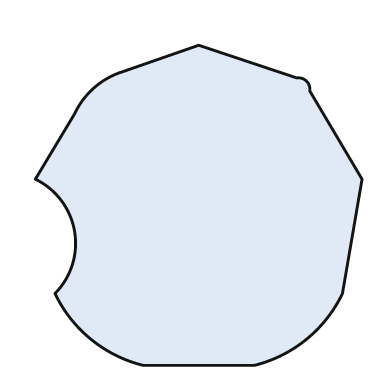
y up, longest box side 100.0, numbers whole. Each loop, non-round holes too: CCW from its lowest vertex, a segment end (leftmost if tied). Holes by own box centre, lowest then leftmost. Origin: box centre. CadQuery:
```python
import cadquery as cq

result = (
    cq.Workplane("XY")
    .moveTo(-17.0, -49.0)
    .lineTo(17.0, -49.0)
    .threePointArc((33.0, -41.0), (44.0, -27.0))
    .lineTo(50.0, 8.0)
    .lineTo(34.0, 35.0)
    .threePointArc((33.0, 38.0), (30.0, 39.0))
    .lineTo(0.0, 49.0)
    .lineTo(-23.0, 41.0)
    .threePointArc((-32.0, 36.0), (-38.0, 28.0))
    .lineTo(-50.0, 8.0)
    .threePointArc((-38.0, -8.0), (-44.0, -27.0))
    .threePointArc((-33.0, -41.0), (-17.0, -49.0))
    .close()
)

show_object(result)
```